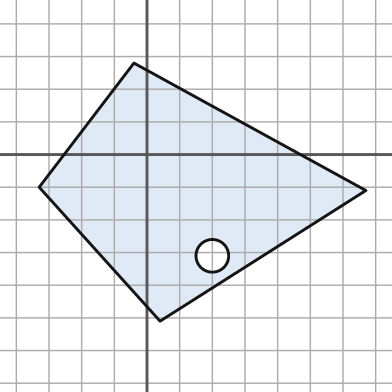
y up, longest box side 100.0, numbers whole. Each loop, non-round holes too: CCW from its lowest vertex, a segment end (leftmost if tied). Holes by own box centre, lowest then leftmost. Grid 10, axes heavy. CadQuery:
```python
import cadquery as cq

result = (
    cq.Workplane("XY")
    .moveTo(4.0, -51.0)
    .lineTo(67.0, -11.0)
    .lineTo(-4.0, 28.0)
    .lineTo(-33.0, -10.0)
    .close()
    .moveTo(20.0, -31.0)
    .circle(5.0)
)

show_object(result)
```